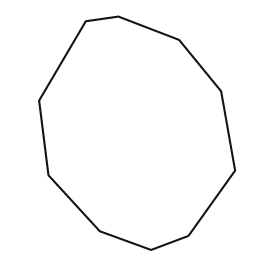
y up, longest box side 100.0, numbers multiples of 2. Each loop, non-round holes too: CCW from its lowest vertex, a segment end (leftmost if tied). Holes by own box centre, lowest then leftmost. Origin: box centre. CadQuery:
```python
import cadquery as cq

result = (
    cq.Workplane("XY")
    .moveTo(6.0, -50.0)
    .lineTo(22.0, -44.0)
    .lineTo(42.0, -16.0)
    .lineTo(36.0, 18.0)
    .lineTo(18.0, 40.0)
    .lineTo(-8.0, 50.0)
    .lineTo(-22.0, 48.0)
    .lineTo(-42.0, 14.0)
    .lineTo(-38.0, -18.0)
    .lineTo(-16.0, -42.0)
    .close()
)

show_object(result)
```